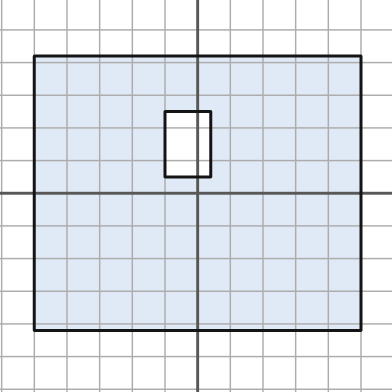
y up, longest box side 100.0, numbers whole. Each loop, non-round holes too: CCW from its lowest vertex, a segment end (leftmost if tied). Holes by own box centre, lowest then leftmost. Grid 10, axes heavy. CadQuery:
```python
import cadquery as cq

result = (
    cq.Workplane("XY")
    .moveTo(-50.0, -42.0)
    .lineTo(50.0, -42.0)
    .lineTo(50.0, 42.0)
    .lineTo(-50.0, 42.0)
    .close()
    .moveTo(-10.0, 5.0)
    .lineTo(4.0, 5.0)
    .lineTo(4.0, 25.0)
    .lineTo(-10.0, 25.0)
    .close()
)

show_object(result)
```